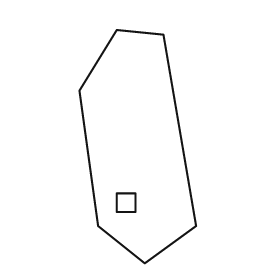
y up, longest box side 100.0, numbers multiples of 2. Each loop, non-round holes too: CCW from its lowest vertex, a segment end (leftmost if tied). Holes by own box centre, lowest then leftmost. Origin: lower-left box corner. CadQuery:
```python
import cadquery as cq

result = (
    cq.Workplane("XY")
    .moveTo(28.0, 0.0)
    .lineTo(50.0, 16.0)
    .lineTo(36.0, 98.0)
    .lineTo(16.0, 100.0)
    .lineTo(0.0, 74.0)
    .lineTo(8.0, 16.0)
    .close()
    .moveTo(16.0, 22.0)
    .lineTo(24.0, 22.0)
    .lineTo(24.0, 30.0)
    .lineTo(16.0, 30.0)
    .close()
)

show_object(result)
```